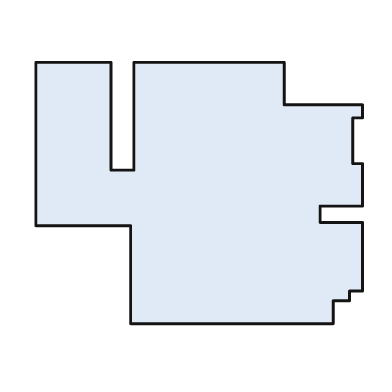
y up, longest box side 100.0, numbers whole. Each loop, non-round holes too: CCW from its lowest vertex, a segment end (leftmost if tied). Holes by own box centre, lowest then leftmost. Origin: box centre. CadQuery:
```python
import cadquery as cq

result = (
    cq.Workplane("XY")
    .moveTo(-21.0, -40.0)
    .lineTo(41.0, -40.0)
    .lineTo(41.0, -33.0)
    .lineTo(46.0, -33.0)
    .lineTo(46.0, -30.0)
    .lineTo(50.0, -30.0)
    .lineTo(50.0, -9.0)
    .lineTo(37.0, -9.0)
    .lineTo(37.0, -4.0)
    .lineTo(50.0, -4.0)
    .lineTo(50.0, 9.0)
    .lineTo(47.0, 9.0)
    .lineTo(47.0, 23.0)
    .lineTo(50.0, 23.0)
    .lineTo(50.0, 27.0)
    .lineTo(26.0, 27.0)
    .lineTo(26.0, 40.0)
    .lineTo(-20.0, 40.0)
    .lineTo(-20.0, 7.0)
    .lineTo(-27.0, 7.0)
    .lineTo(-27.0, 40.0)
    .lineTo(-50.0, 40.0)
    .lineTo(-50.0, -10.0)
    .lineTo(-21.0, -10.0)
    .close()
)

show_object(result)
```